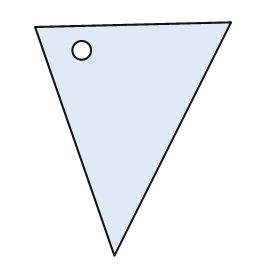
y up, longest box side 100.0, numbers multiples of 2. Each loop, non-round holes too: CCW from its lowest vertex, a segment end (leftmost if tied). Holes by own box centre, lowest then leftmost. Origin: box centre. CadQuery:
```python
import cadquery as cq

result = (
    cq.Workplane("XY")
    .moveTo(-8.0, -50.0)
    .lineTo(42.0, 50.0)
    .lineTo(-42.0, 48.0)
    .close()
    .moveTo(-22.0, 38.0)
    .circle(4.0)
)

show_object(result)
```